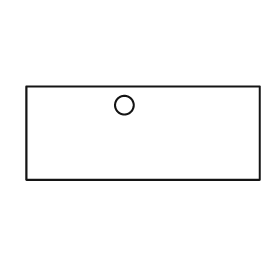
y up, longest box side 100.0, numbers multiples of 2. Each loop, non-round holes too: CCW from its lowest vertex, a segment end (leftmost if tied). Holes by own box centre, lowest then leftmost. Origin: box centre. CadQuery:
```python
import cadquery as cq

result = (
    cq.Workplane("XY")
    .moveTo(-50.0, -20.0)
    .lineTo(50.0, -20.0)
    .lineTo(50.0, 20.0)
    .lineTo(-50.0, 20.0)
    .close()
    .moveTo(-8.0, 12.0)
    .circle(4.0)
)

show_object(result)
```